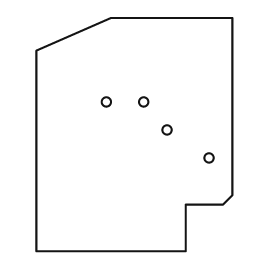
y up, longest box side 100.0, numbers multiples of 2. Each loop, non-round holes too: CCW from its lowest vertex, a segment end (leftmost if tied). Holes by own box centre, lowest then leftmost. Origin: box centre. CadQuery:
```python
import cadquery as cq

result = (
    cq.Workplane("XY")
    .moveTo(-42.0, -50.0)
    .lineTo(22.0, -50.0)
    .lineTo(22.0, -30.0)
    .lineTo(38.0, -30.0)
    .lineTo(42.0, -26.0)
    .lineTo(42.0, 50.0)
    .lineTo(-10.0, 50.0)
    .lineTo(-42.0, 36.0)
    .close()
    .moveTo(32.0, -10.0)
    .circle(2.0)
    .moveTo(14.0, 2.0)
    .circle(2.0)
    .moveTo(-12.0, 14.0)
    .circle(2.0)
    .moveTo(4.0, 14.0)
    .circle(2.0)
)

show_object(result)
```